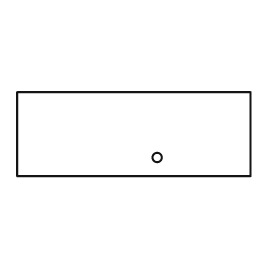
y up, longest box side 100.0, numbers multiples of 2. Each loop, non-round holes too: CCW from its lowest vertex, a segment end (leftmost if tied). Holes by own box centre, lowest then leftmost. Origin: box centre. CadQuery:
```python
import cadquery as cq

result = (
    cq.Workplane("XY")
    .moveTo(-50.0, -18.0)
    .lineTo(50.0, -18.0)
    .lineTo(50.0, 18.0)
    .lineTo(-50.0, 18.0)
    .close()
    .moveTo(10.0, -10.0)
    .circle(2.0)
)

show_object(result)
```